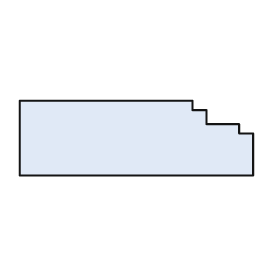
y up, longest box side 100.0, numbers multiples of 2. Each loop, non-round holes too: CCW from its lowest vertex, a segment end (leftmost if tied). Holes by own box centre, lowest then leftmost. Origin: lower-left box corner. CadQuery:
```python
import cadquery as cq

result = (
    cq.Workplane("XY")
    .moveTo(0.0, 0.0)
    .lineTo(100.0, 0.0)
    .lineTo(100.0, 18.0)
    .lineTo(94.0, 18.0)
    .lineTo(94.0, 22.0)
    .lineTo(80.0, 22.0)
    .lineTo(80.0, 28.0)
    .lineTo(74.0, 28.0)
    .lineTo(74.0, 32.0)
    .lineTo(0.0, 32.0)
    .close()
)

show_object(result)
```